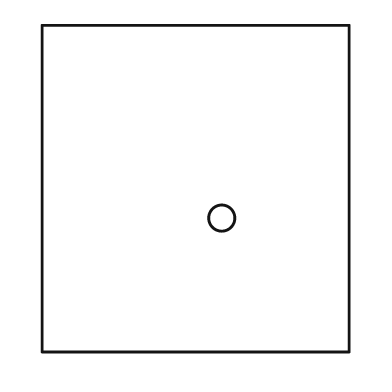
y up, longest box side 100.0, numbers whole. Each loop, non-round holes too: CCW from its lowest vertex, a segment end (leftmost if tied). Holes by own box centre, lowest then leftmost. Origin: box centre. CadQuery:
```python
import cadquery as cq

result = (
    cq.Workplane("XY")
    .moveTo(-47.0, -50.0)
    .lineTo(47.0, -50.0)
    .lineTo(47.0, 50.0)
    .lineTo(-47.0, 50.0)
    .close()
    .moveTo(8.0, -9.0)
    .circle(4.0)
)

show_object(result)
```